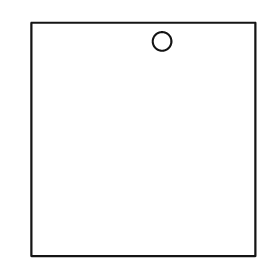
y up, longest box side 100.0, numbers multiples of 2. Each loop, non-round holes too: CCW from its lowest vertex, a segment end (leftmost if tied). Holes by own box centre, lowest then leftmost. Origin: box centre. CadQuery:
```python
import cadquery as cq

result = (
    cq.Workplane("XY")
    .moveTo(-48.0, -50.0)
    .lineTo(48.0, -50.0)
    .lineTo(48.0, 50.0)
    .lineTo(-48.0, 50.0)
    .close()
    .moveTo(8.0, 42.0)
    .circle(4.0)
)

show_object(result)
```